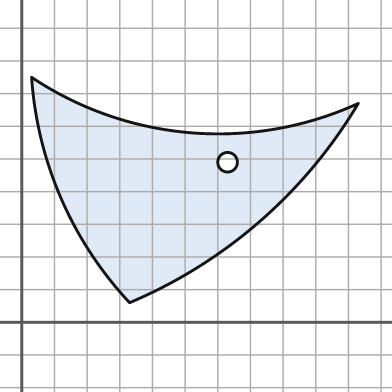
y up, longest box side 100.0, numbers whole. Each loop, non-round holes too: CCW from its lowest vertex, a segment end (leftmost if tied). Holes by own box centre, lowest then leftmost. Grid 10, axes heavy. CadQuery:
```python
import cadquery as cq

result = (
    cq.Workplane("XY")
    .moveTo(33.0, 6.0)
    .threePointArc((73.0, 31.0), (103.0, 67.0))
    .threePointArc((52.0, 58.0), (3.0, 75.0))
    .threePointArc((12.0, 38.0), (33.0, 6.0))
    .close()
    .moveTo(63.0, 49.0)
    .circle(3.0)
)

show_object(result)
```